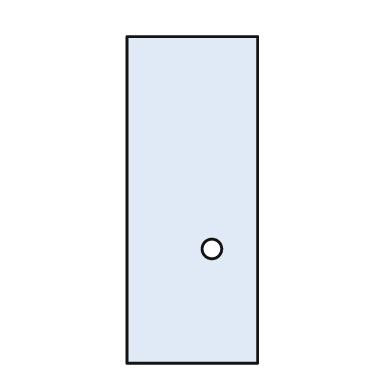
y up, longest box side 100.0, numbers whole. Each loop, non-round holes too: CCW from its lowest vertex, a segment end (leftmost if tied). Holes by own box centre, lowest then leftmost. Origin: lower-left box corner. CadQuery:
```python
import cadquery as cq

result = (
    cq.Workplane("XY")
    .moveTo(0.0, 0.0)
    .lineTo(40.0, 0.0)
    .lineTo(40.0, 100.0)
    .lineTo(0.0, 100.0)
    .close()
    .moveTo(26.0, 35.0)
    .circle(3.0)
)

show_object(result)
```